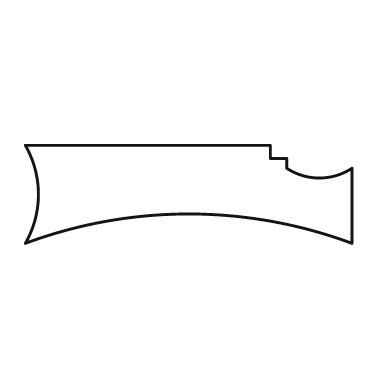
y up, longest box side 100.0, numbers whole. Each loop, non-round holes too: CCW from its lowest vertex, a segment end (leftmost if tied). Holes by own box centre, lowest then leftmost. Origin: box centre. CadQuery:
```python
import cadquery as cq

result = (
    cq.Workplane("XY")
    .moveTo(-50.0, -15.0)
    .threePointArc((0.0, -6.0), (50.0, -15.0))
    .lineTo(50.0, 8.0)
    .threePointArc((40.0, 5.0), (30.0, 8.0))
    .lineTo(30.0, 11.0)
    .lineTo(25.0, 11.0)
    .lineTo(25.0, 15.0)
    .lineTo(-50.0, 15.0)
    .threePointArc((-46.0, 0.0), (-50.0, -15.0))
    .close()
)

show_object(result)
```